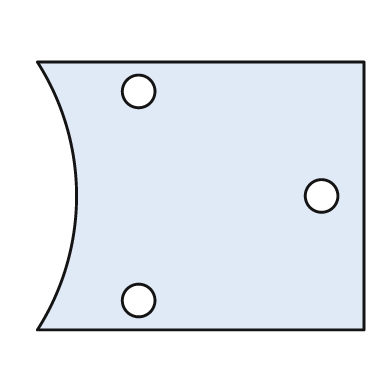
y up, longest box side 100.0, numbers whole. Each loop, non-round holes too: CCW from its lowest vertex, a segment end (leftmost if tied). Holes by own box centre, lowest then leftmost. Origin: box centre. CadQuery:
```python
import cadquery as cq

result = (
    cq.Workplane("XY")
    .moveTo(-50.0, -41.0)
    .lineTo(50.0, -41.0)
    .lineTo(50.0, 41.0)
    .lineTo(-50.0, 41.0)
    .threePointArc((-38.0, 0.0), (-50.0, -41.0))
    .close()
    .moveTo(-19.0, -32.0)
    .circle(5.0)
    .moveTo(37.0, 0.0)
    .circle(5.0)
    .moveTo(-19.0, 32.0)
    .circle(5.0)
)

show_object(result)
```